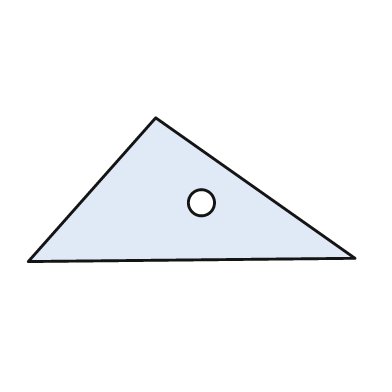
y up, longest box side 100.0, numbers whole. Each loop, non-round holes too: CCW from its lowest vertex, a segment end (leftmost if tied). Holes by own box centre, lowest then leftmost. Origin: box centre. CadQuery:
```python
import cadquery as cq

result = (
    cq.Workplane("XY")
    .moveTo(-50.0, -22.0)
    .lineTo(50.0, -21.0)
    .lineTo(-11.0, 22.0)
    .close()
    .moveTo(3.0, -4.0)
    .circle(4.0)
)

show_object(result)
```